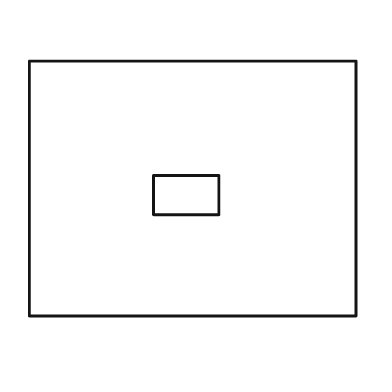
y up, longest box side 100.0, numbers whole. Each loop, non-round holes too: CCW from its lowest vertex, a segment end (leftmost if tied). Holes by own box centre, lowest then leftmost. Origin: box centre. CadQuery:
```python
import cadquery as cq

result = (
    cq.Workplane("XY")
    .moveTo(-50.0, -39.0)
    .lineTo(50.0, -39.0)
    .lineTo(50.0, 39.0)
    .lineTo(-50.0, 39.0)
    .close()
    .moveTo(-12.0, -8.0)
    .lineTo(8.0, -8.0)
    .lineTo(8.0, 4.0)
    .lineTo(-12.0, 4.0)
    .close()
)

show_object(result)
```